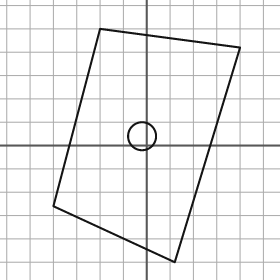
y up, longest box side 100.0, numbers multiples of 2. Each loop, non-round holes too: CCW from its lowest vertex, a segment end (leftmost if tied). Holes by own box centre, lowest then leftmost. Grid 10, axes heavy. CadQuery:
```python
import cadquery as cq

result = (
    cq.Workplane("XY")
    .moveTo(12.0, -50.0)
    .lineTo(40.0, 42.0)
    .lineTo(-20.0, 50.0)
    .lineTo(-40.0, -26.0)
    .close()
    .moveTo(-2.0, 4.0)
    .circle(6.0)
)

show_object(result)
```